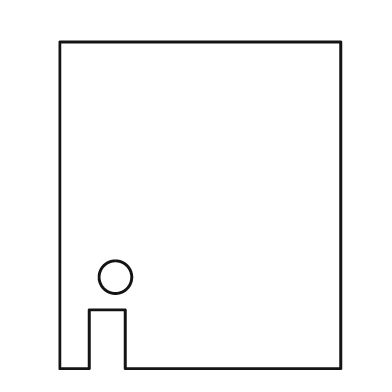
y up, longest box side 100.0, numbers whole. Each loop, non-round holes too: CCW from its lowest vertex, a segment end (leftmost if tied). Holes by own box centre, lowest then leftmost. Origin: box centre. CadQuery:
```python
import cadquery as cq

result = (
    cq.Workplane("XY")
    .moveTo(-43.0, -50.0)
    .lineTo(-34.0, -50.0)
    .lineTo(-34.0, -32.0)
    .lineTo(-23.0, -32.0)
    .lineTo(-23.0, -50.0)
    .lineTo(43.0, -50.0)
    .lineTo(43.0, 50.0)
    .lineTo(-43.0, 50.0)
    .close()
    .moveTo(-26.0, -22.0)
    .circle(5.0)
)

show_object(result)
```